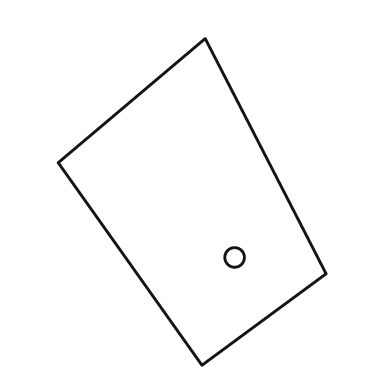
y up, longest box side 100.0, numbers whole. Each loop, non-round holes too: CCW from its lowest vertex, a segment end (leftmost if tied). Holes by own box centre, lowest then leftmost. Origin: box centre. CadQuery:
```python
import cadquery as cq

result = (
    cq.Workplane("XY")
    .moveTo(3.0, -50.0)
    .lineTo(41.0, -22.0)
    .lineTo(4.0, 50.0)
    .lineTo(-41.0, 12.0)
    .close()
    .moveTo(13.0, -17.0)
    .circle(3.0)
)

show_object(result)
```